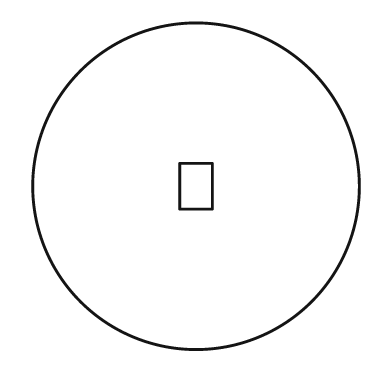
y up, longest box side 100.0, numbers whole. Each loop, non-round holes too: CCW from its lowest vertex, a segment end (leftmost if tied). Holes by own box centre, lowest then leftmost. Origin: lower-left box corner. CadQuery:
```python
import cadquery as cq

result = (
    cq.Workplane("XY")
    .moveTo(50.0, 50.0)
    .circle(50.0)
    .moveTo(45.0, 43.0)
    .lineTo(55.0, 43.0)
    .lineTo(55.0, 57.0)
    .lineTo(45.0, 57.0)
    .close()
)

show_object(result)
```